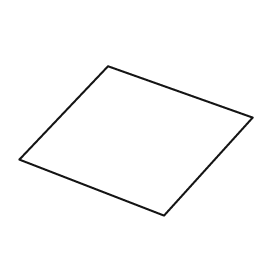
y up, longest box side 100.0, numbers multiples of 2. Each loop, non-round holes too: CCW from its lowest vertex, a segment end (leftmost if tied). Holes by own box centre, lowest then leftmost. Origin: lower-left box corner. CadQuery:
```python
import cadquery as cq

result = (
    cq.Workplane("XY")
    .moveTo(62.0, 0.0)
    .lineTo(100.0, 42.0)
    .lineTo(38.0, 64.0)
    .lineTo(0.0, 24.0)
    .close()
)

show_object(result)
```